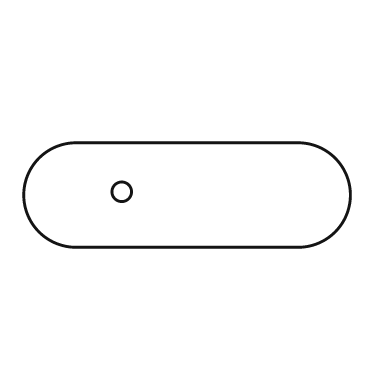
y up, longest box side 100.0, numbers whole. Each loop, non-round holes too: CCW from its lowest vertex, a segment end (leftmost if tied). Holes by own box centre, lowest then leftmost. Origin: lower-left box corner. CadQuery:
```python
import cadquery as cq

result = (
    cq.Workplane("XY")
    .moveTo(16.0, 0.0)
    .lineTo(84.0, 0.0)
    .threePointArc((100.0, 16.0), (84.0, 32.0))
    .lineTo(16.0, 32.0)
    .threePointArc((0.0, 16.0), (16.0, 0.0))
    .close()
    .moveTo(30.0, 17.0)
    .circle(3.0)
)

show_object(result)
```